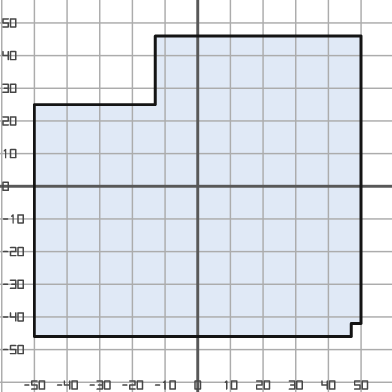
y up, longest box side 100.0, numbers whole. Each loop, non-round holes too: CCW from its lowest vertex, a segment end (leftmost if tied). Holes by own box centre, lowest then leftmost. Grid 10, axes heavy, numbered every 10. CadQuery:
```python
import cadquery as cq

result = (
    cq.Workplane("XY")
    .moveTo(-50.0, -46.0)
    .lineTo(47.0, -46.0)
    .lineTo(47.0, -42.0)
    .lineTo(50.0, -42.0)
    .lineTo(50.0, 46.0)
    .lineTo(-13.0, 46.0)
    .lineTo(-13.0, 25.0)
    .lineTo(-50.0, 25.0)
    .close()
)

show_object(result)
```